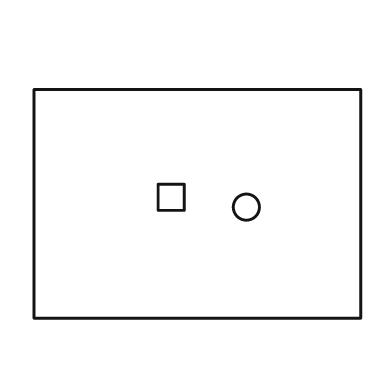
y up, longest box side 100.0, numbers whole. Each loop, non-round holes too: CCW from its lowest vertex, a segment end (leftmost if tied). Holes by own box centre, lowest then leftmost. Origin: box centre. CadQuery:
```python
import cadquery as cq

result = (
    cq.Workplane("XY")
    .moveTo(-50.0, -35.0)
    .lineTo(50.0, -35.0)
    .lineTo(50.0, 35.0)
    .lineTo(-50.0, 35.0)
    .close()
    .moveTo(15.0, -1.0)
    .circle(4.0)
    .moveTo(-12.0, -2.0)
    .lineTo(-4.0, -2.0)
    .lineTo(-4.0, 6.0)
    .lineTo(-12.0, 6.0)
    .close()
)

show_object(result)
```